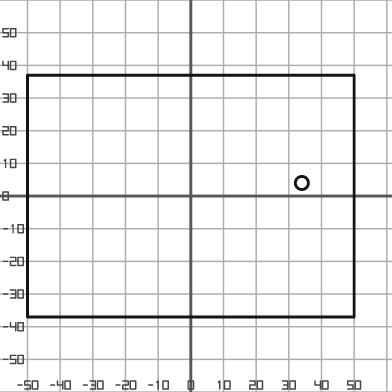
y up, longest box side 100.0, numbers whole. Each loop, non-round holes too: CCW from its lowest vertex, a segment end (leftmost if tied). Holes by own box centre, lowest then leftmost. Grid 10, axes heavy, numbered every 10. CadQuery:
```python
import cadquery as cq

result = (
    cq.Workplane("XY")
    .moveTo(-50.0, -37.0)
    .lineTo(50.0, -37.0)
    .lineTo(50.0, 37.0)
    .lineTo(-50.0, 37.0)
    .close()
    .moveTo(34.0, 4.0)
    .circle(2.0)
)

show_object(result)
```